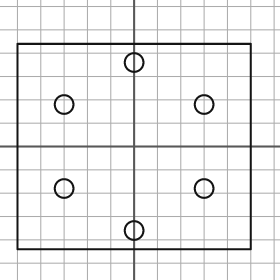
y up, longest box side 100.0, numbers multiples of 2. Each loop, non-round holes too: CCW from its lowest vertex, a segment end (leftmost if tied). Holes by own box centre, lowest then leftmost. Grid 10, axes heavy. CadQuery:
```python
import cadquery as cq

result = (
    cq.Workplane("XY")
    .moveTo(-50.0, -44.0)
    .lineTo(50.0, -44.0)
    .lineTo(50.0, 44.0)
    .lineTo(-50.0, 44.0)
    .close()
    .moveTo(0.0, -36.0)
    .circle(4.0)
    .moveTo(-30.0, -18.0)
    .circle(4.0)
    .moveTo(30.0, -18.0)
    .circle(4.0)
    .moveTo(-30.0, 18.0)
    .circle(4.0)
    .moveTo(30.0, 18.0)
    .circle(4.0)
    .moveTo(0.0, 36.0)
    .circle(4.0)
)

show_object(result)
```